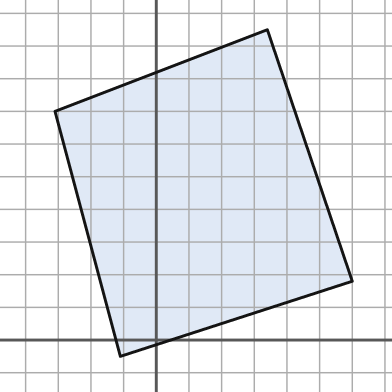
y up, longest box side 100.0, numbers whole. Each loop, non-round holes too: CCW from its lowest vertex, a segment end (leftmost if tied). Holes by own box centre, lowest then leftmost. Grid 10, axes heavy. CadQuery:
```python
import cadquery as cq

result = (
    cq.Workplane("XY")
    .moveTo(-11.0, -5.0)
    .lineTo(60.0, 18.0)
    .lineTo(34.0, 95.0)
    .lineTo(-31.0, 70.0)
    .close()
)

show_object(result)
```